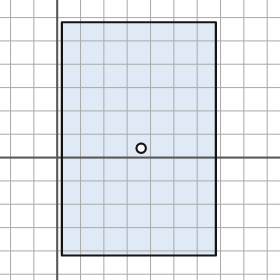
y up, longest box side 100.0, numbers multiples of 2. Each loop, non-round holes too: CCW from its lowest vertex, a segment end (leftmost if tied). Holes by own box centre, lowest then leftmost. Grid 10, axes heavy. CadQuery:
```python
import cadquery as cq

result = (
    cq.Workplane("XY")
    .moveTo(2.0, -42.0)
    .lineTo(68.0, -42.0)
    .lineTo(68.0, 58.0)
    .lineTo(2.0, 58.0)
    .close()
    .moveTo(36.0, 4.0)
    .circle(2.0)
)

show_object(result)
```